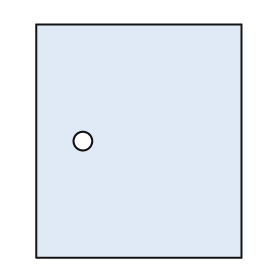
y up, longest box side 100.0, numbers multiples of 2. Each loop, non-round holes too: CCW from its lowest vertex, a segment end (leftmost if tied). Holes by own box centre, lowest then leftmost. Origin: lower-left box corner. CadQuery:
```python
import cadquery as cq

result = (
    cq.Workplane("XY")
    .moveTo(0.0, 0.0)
    .lineTo(88.0, 0.0)
    .lineTo(88.0, 100.0)
    .lineTo(0.0, 100.0)
    .close()
    .moveTo(20.0, 50.0)
    .circle(4.0)
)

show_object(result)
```